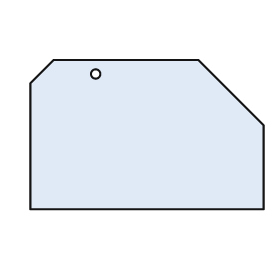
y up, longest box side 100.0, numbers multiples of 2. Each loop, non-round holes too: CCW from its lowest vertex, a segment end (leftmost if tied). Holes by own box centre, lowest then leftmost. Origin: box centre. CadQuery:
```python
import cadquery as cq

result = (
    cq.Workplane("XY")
    .moveTo(-50.0, -32.0)
    .lineTo(50.0, -32.0)
    .lineTo(50.0, 4.0)
    .lineTo(22.0, 32.0)
    .lineTo(-40.0, 32.0)
    .lineTo(-50.0, 22.0)
    .close()
    .moveTo(-22.0, 26.0)
    .circle(2.0)
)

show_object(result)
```